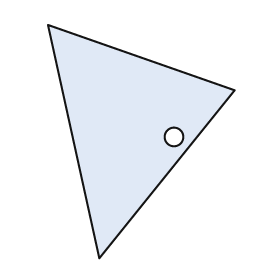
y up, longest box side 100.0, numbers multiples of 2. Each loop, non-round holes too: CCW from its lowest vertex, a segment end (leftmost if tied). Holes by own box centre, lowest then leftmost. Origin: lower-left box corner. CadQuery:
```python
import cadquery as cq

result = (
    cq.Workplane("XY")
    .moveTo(22.0, 0.0)
    .lineTo(80.0, 72.0)
    .lineTo(0.0, 100.0)
    .close()
    .moveTo(54.0, 52.0)
    .circle(4.0)
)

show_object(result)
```